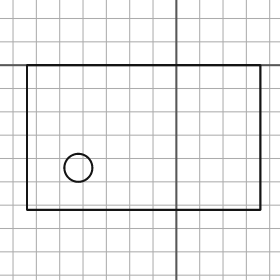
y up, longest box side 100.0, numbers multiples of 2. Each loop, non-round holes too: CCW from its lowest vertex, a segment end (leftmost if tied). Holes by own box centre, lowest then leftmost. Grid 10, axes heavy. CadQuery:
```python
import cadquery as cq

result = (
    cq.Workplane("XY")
    .moveTo(-64.0, -62.0)
    .lineTo(36.0, -62.0)
    .lineTo(36.0, 0.0)
    .lineTo(-64.0, 0.0)
    .close()
    .moveTo(-42.0, -44.0)
    .circle(6.0)
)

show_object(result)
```